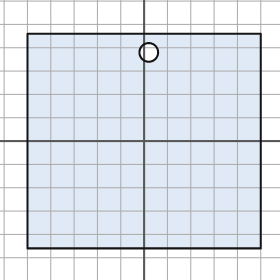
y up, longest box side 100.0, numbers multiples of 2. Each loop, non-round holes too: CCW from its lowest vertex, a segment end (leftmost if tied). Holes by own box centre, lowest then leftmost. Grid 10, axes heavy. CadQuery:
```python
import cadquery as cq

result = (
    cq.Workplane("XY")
    .moveTo(-50.0, -46.0)
    .lineTo(50.0, -46.0)
    .lineTo(50.0, 46.0)
    .lineTo(-50.0, 46.0)
    .close()
    .moveTo(2.0, 38.0)
    .circle(4.0)
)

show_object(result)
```